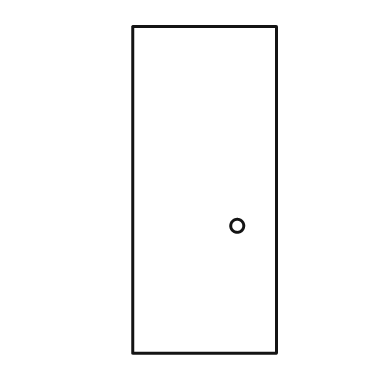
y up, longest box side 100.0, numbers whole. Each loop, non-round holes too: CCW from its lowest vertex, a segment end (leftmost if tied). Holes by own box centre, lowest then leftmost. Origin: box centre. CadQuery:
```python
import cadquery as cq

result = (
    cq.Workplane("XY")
    .moveTo(-22.0, -50.0)
    .lineTo(22.0, -50.0)
    .lineTo(22.0, 50.0)
    .lineTo(-22.0, 50.0)
    .close()
    .moveTo(10.0, -11.0)
    .circle(2.0)
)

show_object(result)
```